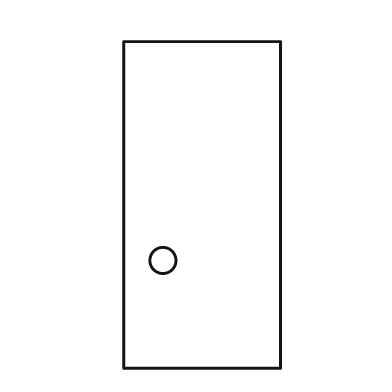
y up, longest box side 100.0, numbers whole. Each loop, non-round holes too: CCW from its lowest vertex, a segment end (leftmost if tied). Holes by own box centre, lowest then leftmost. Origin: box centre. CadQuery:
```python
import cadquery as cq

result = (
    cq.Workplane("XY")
    .moveTo(-24.0, -50.0)
    .lineTo(24.0, -50.0)
    .lineTo(24.0, 50.0)
    .lineTo(-24.0, 50.0)
    .close()
    .moveTo(-12.0, -17.0)
    .circle(4.0)
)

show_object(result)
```